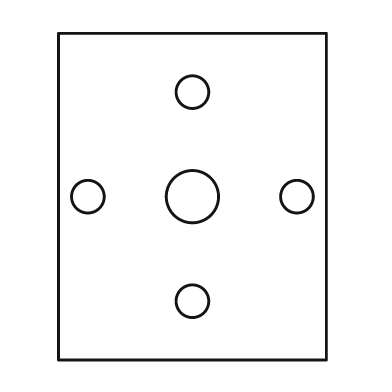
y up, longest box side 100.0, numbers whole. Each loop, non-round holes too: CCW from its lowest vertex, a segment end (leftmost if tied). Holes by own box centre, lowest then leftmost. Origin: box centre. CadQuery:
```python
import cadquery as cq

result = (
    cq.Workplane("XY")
    .moveTo(-41.0, -50.0)
    .lineTo(41.0, -50.0)
    .lineTo(41.0, 50.0)
    .lineTo(-41.0, 50.0)
    .close()
    .moveTo(0.0, -32.0)
    .circle(5.0)
    .moveTo(-32.0, 0.0)
    .circle(5.0)
    .moveTo(0.0, 0.0)
    .circle(8.0)
    .moveTo(32.0, 0.0)
    .circle(5.0)
    .moveTo(0.0, 32.0)
    .circle(5.0)
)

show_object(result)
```